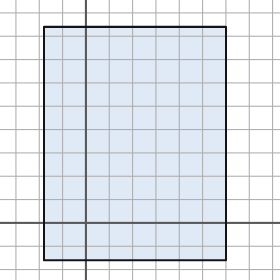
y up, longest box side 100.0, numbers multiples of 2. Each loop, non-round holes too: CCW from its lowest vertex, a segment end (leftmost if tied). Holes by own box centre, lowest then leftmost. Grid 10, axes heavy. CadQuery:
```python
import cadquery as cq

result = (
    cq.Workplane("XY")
    .moveTo(-18.0, -16.0)
    .lineTo(60.0, -16.0)
    .lineTo(60.0, 84.0)
    .lineTo(-18.0, 84.0)
    .close()
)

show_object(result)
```